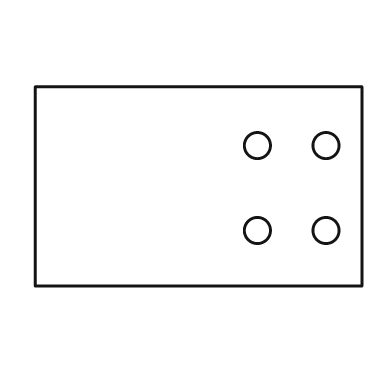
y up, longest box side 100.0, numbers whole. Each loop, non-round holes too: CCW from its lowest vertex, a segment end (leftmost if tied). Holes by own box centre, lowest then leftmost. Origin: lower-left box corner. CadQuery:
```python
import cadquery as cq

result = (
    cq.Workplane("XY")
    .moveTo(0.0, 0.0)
    .lineTo(100.0, 0.0)
    .lineTo(100.0, 61.0)
    .lineTo(0.0, 61.0)
    .close()
    .moveTo(68.0, 17.0)
    .circle(4.0)
    .moveTo(89.0, 17.0)
    .circle(4.0)
    .moveTo(68.0, 43.0)
    .circle(4.0)
    .moveTo(89.0, 43.0)
    .circle(4.0)
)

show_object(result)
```